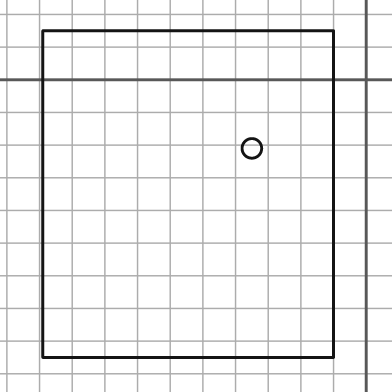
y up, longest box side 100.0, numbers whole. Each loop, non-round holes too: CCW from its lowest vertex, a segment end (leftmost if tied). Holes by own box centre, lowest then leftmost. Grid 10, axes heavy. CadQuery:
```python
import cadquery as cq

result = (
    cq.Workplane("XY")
    .moveTo(-99.0, -85.0)
    .lineTo(-10.0, -85.0)
    .lineTo(-10.0, 15.0)
    .lineTo(-99.0, 15.0)
    .close()
    .moveTo(-35.0, -21.0)
    .circle(3.0)
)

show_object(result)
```